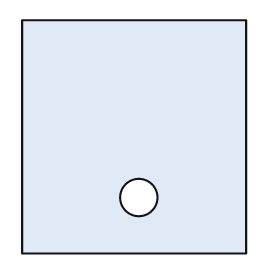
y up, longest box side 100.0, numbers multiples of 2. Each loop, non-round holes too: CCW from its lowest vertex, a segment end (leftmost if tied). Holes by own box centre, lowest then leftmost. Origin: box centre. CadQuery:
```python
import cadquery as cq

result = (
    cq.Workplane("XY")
    .moveTo(-48.0, -50.0)
    .lineTo(48.0, -50.0)
    .lineTo(48.0, 50.0)
    .lineTo(-48.0, 50.0)
    .close()
    .moveTo(2.0, -26.0)
    .circle(8.0)
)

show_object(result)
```